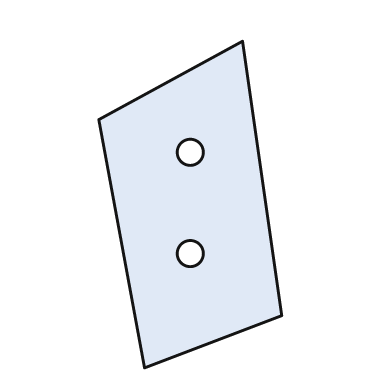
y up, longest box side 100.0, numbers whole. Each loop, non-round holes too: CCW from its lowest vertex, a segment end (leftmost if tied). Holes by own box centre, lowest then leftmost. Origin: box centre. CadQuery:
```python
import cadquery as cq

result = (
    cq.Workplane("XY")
    .moveTo(-14.0, -50.0)
    .lineTo(28.0, -34.0)
    .lineTo(16.0, 50.0)
    .lineTo(-28.0, 26.0)
    .close()
    .moveTo(0.0, -15.0)
    .circle(4.0)
    .moveTo(0.0, 16.0)
    .circle(4.0)
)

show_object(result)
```